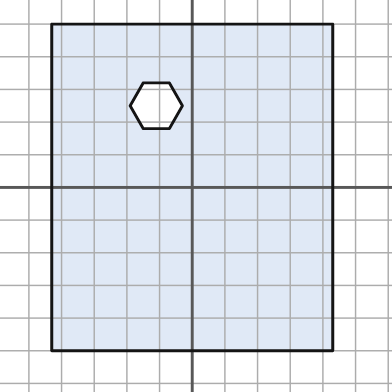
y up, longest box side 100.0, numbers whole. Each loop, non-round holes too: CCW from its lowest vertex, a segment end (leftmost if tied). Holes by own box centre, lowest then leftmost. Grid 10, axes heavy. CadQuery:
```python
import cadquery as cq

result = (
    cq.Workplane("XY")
    .moveTo(-43.0, -50.0)
    .lineTo(43.0, -50.0)
    .lineTo(43.0, 50.0)
    .lineTo(-43.0, 50.0)
    .close()
    .moveTo(-15.0, 18.0)
    .lineTo(-7.0, 18.0)
    .lineTo(-3.0, 25.0)
    .lineTo(-7.0, 32.0)
    .lineTo(-15.0, 32.0)
    .lineTo(-19.0, 25.0)
    .close()
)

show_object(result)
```